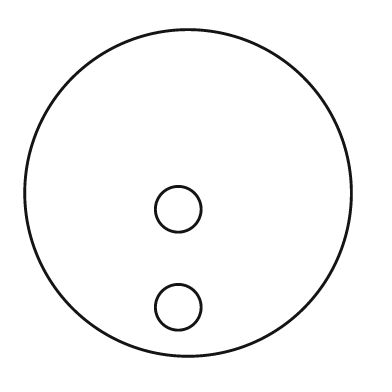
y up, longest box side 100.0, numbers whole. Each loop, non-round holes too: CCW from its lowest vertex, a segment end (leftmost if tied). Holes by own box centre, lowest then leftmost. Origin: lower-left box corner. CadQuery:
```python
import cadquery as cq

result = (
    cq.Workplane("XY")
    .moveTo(50.0, 50.0)
    .circle(50.0)
    .moveTo(47.0, 15.0)
    .circle(7.0)
    .moveTo(47.0, 45.0)
    .circle(7.0)
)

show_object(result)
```